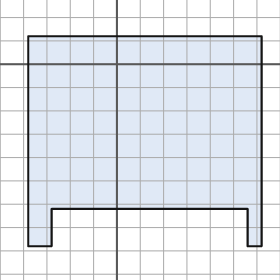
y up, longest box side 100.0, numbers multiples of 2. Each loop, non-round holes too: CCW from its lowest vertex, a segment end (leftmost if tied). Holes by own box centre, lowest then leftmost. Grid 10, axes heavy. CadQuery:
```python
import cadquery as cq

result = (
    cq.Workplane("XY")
    .moveTo(-38.0, -78.0)
    .lineTo(-28.0, -78.0)
    .lineTo(-28.0, -62.0)
    .lineTo(56.0, -62.0)
    .lineTo(56.0, -78.0)
    .lineTo(62.0, -78.0)
    .lineTo(62.0, 12.0)
    .lineTo(-38.0, 12.0)
    .close()
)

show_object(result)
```